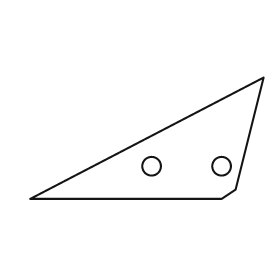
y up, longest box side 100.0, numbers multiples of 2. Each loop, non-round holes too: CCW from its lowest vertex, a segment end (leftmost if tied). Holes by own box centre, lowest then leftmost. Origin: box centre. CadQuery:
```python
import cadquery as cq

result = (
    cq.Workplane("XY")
    .moveTo(-50.0, -26.0)
    .lineTo(32.0, -26.0)
    .lineTo(38.0, -22.0)
    .lineTo(50.0, 26.0)
    .close()
    .moveTo(2.0, -12.0)
    .circle(4.0)
    .moveTo(32.0, -12.0)
    .circle(4.0)
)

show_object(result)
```